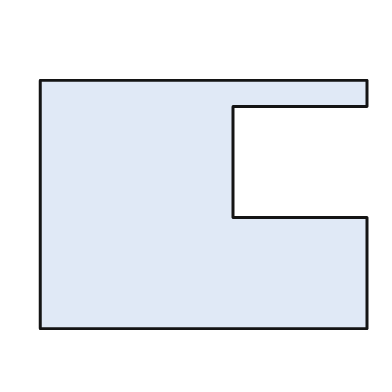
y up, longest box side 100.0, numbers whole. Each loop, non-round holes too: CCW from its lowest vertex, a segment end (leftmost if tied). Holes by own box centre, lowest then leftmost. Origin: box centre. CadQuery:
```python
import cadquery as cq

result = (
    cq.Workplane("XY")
    .moveTo(-50.0, -38.0)
    .lineTo(50.0, -38.0)
    .lineTo(50.0, -4.0)
    .lineTo(9.0, -4.0)
    .lineTo(9.0, 30.0)
    .lineTo(50.0, 30.0)
    .lineTo(50.0, 38.0)
    .lineTo(-50.0, 38.0)
    .close()
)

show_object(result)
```